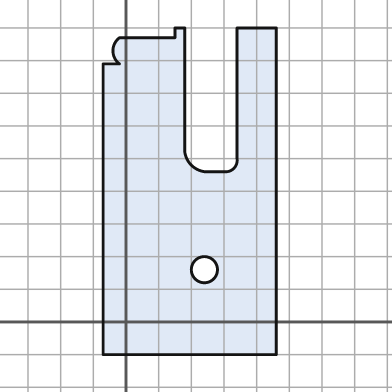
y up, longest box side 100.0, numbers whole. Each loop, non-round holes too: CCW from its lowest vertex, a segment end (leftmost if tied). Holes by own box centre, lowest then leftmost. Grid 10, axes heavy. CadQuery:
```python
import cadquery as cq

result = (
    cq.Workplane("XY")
    .moveTo(-7.0, -10.0)
    .lineTo(46.0, -10.0)
    .lineTo(46.0, 90.0)
    .lineTo(34.0, 90.0)
    .lineTo(34.0, 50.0)
    .threePointArc((33.0, 47.0), (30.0, 46.0))
    .lineTo(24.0, 46.0)
    .threePointArc((20.0, 48.0), (18.0, 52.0))
    .lineTo(18.0, 90.0)
    .lineTo(15.0, 90.0)
    .lineTo(15.0, 87.0)
    .lineTo(-2.0, 87.0)
    .threePointArc((-4.0, 83.0), (-2.0, 79.0))
    .lineTo(-7.0, 79.0)
    .close()
    .moveTo(24.0, 16.0)
    .circle(4.0)
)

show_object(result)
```